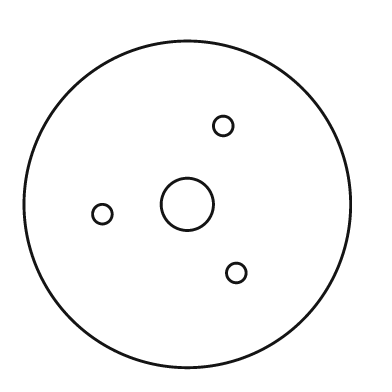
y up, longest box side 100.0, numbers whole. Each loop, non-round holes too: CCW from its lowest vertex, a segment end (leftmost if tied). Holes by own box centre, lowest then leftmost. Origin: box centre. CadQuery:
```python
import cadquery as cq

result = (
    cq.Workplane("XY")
    .moveTo(0.0, 0.0)
    .circle(50.0)
    .moveTo(15.0, -21.0)
    .circle(3.0)
    .moveTo(-26.0, -3.0)
    .circle(3.0)
    .moveTo(0.0, 0.0)
    .circle(8.0)
    .moveTo(11.0, 24.0)
    .circle(3.0)
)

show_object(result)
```